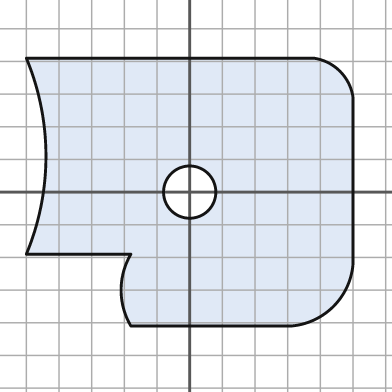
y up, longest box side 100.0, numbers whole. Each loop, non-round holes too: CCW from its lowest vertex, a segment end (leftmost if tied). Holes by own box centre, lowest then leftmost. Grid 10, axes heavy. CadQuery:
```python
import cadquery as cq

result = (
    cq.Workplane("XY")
    .moveTo(-18.0, -41.0)
    .lineTo(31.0, -41.0)
    .threePointArc((44.0, -35.0), (50.0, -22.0))
    .lineTo(50.0, 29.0)
    .threePointArc((46.0, 37.0), (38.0, 41.0))
    .lineTo(-50.0, 41.0)
    .threePointArc((-44.0, 11.0), (-50.0, -19.0))
    .lineTo(-18.0, -19.0)
    .threePointArc((-21.0, -30.0), (-18.0, -41.0))
    .close()
    .moveTo(0.0, 0.0)
    .circle(8.0)
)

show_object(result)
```